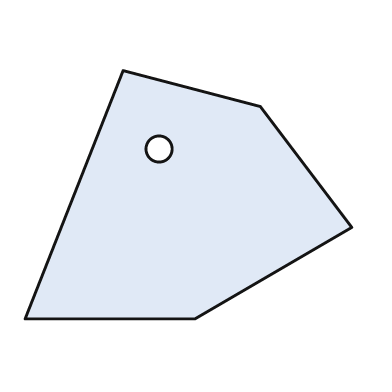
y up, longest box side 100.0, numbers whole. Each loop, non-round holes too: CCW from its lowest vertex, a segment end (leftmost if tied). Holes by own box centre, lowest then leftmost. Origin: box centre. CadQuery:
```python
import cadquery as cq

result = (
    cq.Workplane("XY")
    .moveTo(-50.0, -38.0)
    .lineTo(2.0, -38.0)
    .lineTo(50.0, -10.0)
    .lineTo(22.0, 27.0)
    .lineTo(-20.0, 38.0)
    .close()
    .moveTo(-9.0, 14.0)
    .circle(4.0)
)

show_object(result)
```